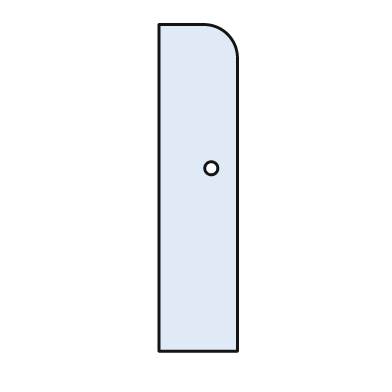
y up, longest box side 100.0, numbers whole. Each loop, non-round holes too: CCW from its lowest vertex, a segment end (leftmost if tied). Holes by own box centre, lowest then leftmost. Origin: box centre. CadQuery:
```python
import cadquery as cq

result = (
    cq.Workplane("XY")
    .moveTo(-12.0, -50.0)
    .lineTo(12.0, -50.0)
    .lineTo(12.0, 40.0)
    .threePointArc((9.0, 47.0), (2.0, 50.0))
    .lineTo(-12.0, 50.0)
    .close()
    .moveTo(4.0, 6.0)
    .circle(2.0)
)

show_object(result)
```